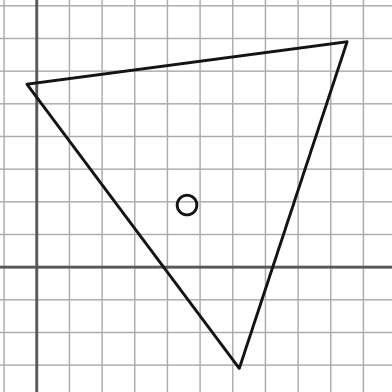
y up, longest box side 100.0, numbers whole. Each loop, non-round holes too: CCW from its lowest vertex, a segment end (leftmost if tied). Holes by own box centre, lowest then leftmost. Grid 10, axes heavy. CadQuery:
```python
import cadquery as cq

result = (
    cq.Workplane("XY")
    .moveTo(62.0, -31.0)
    .lineTo(95.0, 69.0)
    .lineTo(-3.0, 56.0)
    .close()
    .moveTo(46.0, 19.0)
    .circle(3.0)
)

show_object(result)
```